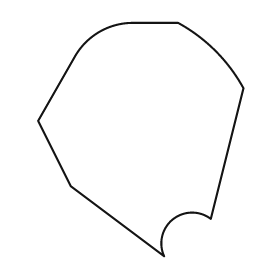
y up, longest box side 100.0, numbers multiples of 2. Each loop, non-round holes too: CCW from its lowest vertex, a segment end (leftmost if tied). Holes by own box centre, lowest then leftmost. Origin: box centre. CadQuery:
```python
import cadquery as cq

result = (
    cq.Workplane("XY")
    .moveTo(10.0, -50.0)
    .threePointArc((14.0, -34.0), (30.0, -34.0))
    .lineTo(44.0, 22.0)
    .threePointArc((32.0, 38.0), (16.0, 50.0))
    .lineTo(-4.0, 50.0)
    .threePointArc((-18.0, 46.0), (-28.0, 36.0))
    .lineTo(-44.0, 8.0)
    .lineTo(-30.0, -20.0)
    .close()
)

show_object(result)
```